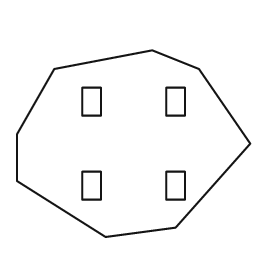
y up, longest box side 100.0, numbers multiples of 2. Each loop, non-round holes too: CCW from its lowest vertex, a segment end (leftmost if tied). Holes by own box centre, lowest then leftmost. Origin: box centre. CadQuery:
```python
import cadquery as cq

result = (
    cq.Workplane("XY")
    .moveTo(-12.0, -40.0)
    .lineTo(18.0, -36.0)
    .lineTo(50.0, 0.0)
    .lineTo(28.0, 32.0)
    .lineTo(8.0, 40.0)
    .lineTo(-34.0, 32.0)
    .lineTo(-50.0, 4.0)
    .lineTo(-50.0, -16.0)
    .close()
    .moveTo(-22.0, -24.0)
    .lineTo(-14.0, -24.0)
    .lineTo(-14.0, -12.0)
    .lineTo(-22.0, -12.0)
    .close()
    .moveTo(14.0, -24.0)
    .lineTo(22.0, -24.0)
    .lineTo(22.0, -12.0)
    .lineTo(14.0, -12.0)
    .close()
    .moveTo(-22.0, 12.0)
    .lineTo(-14.0, 12.0)
    .lineTo(-14.0, 24.0)
    .lineTo(-22.0, 24.0)
    .close()
    .moveTo(14.0, 12.0)
    .lineTo(22.0, 12.0)
    .lineTo(22.0, 24.0)
    .lineTo(14.0, 24.0)
    .close()
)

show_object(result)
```